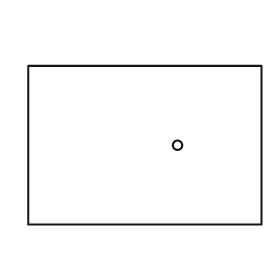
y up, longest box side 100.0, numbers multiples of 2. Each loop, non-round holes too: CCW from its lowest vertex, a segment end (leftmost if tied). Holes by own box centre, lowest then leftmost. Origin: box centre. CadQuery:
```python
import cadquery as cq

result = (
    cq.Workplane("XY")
    .moveTo(-50.0, -34.0)
    .lineTo(50.0, -34.0)
    .lineTo(50.0, 34.0)
    .lineTo(-50.0, 34.0)
    .close()
    .moveTo(14.0, 0.0)
    .circle(2.0)
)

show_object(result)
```